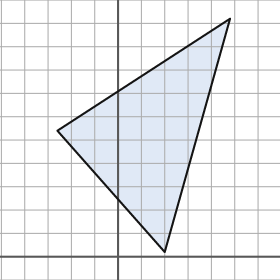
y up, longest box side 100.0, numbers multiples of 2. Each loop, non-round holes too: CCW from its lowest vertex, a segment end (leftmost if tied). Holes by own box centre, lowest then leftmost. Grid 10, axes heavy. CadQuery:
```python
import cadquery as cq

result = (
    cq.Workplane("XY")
    .moveTo(20.0, 2.0)
    .lineTo(48.0, 102.0)
    .lineTo(-26.0, 54.0)
    .close()
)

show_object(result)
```